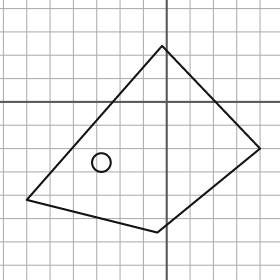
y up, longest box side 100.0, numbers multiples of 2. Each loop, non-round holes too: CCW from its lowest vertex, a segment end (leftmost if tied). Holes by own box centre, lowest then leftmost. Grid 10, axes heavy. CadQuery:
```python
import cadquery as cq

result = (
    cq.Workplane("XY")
    .moveTo(-4.0, -56.0)
    .lineTo(40.0, -20.0)
    .lineTo(-2.0, 24.0)
    .lineTo(-60.0, -42.0)
    .close()
    .moveTo(-28.0, -26.0)
    .circle(4.0)
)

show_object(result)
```